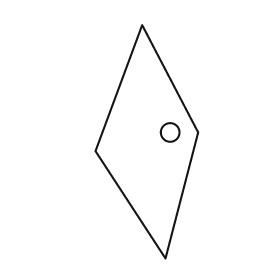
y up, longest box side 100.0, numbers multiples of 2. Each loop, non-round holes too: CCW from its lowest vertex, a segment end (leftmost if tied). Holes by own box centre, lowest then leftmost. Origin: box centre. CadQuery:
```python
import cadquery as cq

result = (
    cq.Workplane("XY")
    .moveTo(8.0, -50.0)
    .lineTo(22.0, 4.0)
    .lineTo(-2.0, 50.0)
    .lineTo(-22.0, -4.0)
    .close()
    .moveTo(10.0, 4.0)
    .circle(4.0)
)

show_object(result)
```